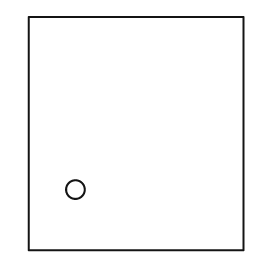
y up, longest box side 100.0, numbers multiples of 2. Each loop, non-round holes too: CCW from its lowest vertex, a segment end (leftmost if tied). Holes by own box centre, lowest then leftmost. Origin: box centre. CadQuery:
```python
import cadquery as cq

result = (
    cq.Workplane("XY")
    .moveTo(-46.0, -50.0)
    .lineTo(46.0, -50.0)
    .lineTo(46.0, 50.0)
    .lineTo(-46.0, 50.0)
    .close()
    .moveTo(-26.0, -24.0)
    .circle(4.0)
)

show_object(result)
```